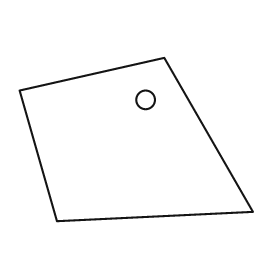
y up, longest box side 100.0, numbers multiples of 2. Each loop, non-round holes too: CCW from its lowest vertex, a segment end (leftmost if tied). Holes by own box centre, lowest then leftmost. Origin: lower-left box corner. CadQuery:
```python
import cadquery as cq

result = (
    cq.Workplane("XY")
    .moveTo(16.0, 0.0)
    .lineTo(100.0, 4.0)
    .lineTo(62.0, 70.0)
    .lineTo(0.0, 56.0)
    .close()
    .moveTo(54.0, 52.0)
    .circle(4.0)
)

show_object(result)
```